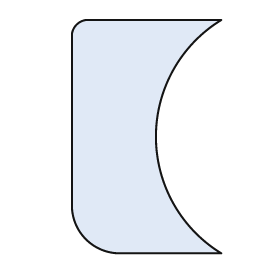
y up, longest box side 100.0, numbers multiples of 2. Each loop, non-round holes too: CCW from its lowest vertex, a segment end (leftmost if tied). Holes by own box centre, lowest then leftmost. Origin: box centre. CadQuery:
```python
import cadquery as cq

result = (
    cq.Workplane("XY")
    .moveTo(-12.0, -50.0)
    .lineTo(32.0, -50.0)
    .threePointArc((4.0, 0.0), (32.0, 50.0))
    .lineTo(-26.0, 50.0)
    .threePointArc((-30.0, 48.0), (-32.0, 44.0))
    .lineTo(-32.0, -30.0)
    .threePointArc((-26.0, -44.0), (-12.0, -50.0))
    .close()
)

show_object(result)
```